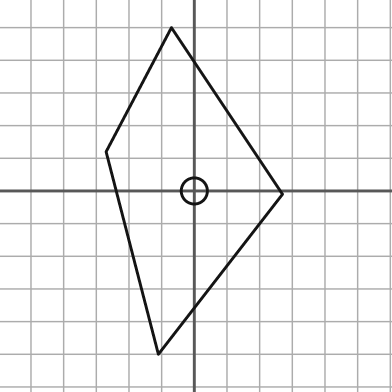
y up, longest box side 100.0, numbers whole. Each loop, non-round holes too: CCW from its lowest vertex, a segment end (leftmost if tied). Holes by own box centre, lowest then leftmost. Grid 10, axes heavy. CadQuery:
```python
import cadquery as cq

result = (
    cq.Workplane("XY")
    .moveTo(-11.0, -50.0)
    .lineTo(27.0, -1.0)
    .lineTo(-7.0, 50.0)
    .lineTo(-27.0, 12.0)
    .close()
    .moveTo(0.0, 0.0)
    .circle(4.0)
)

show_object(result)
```